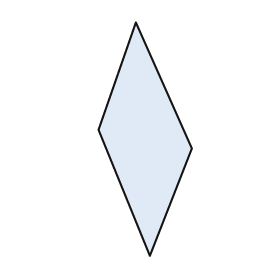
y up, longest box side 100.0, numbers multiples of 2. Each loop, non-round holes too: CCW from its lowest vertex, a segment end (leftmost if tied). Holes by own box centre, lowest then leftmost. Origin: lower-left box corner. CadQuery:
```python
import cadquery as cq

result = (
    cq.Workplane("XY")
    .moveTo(22.0, 0.0)
    .lineTo(40.0, 46.0)
    .lineTo(16.0, 100.0)
    .lineTo(0.0, 54.0)
    .close()
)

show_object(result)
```